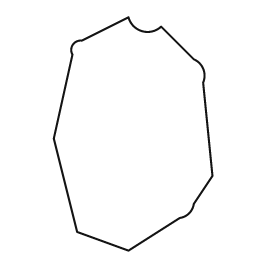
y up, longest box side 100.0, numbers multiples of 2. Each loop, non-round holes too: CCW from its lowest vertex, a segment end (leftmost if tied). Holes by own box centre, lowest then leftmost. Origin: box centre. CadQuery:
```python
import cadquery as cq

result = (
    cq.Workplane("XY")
    .moveTo(-2.0, -50.0)
    .lineTo(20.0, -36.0)
    .threePointArc((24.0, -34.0), (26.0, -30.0))
    .lineTo(34.0, -18.0)
    .lineTo(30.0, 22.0)
    .threePointArc((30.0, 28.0), (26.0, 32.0))
    .lineTo(12.0, 46.0)
    .threePointArc((4.0, 44.0), (-2.0, 50.0))
    .lineTo(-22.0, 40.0)
    .threePointArc((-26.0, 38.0), (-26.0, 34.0))
    .lineTo(-34.0, -2.0)
    .lineTo(-24.0, -42.0)
    .close()
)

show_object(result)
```